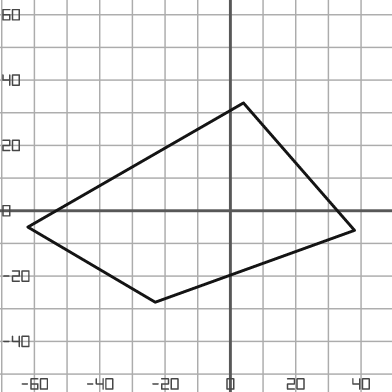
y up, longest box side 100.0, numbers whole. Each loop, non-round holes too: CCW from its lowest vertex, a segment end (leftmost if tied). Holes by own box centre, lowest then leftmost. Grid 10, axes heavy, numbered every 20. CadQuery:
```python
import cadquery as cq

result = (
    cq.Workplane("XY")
    .moveTo(-23.0, -28.0)
    .lineTo(38.0, -6.0)
    .lineTo(4.0, 33.0)
    .lineTo(-62.0, -5.0)
    .close()
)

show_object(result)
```